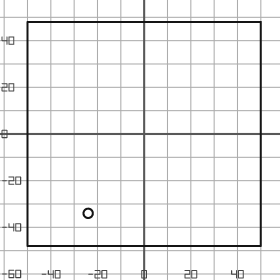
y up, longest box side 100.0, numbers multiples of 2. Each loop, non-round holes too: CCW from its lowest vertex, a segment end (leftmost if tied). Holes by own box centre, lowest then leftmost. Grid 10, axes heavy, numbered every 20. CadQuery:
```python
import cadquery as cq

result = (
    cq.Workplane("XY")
    .moveTo(-50.0, -48.0)
    .lineTo(50.0, -48.0)
    .lineTo(50.0, 48.0)
    .lineTo(-50.0, 48.0)
    .close()
    .moveTo(-24.0, -34.0)
    .circle(2.0)
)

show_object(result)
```